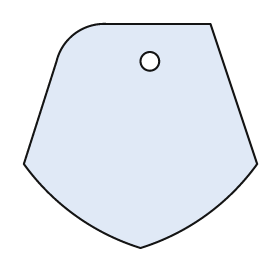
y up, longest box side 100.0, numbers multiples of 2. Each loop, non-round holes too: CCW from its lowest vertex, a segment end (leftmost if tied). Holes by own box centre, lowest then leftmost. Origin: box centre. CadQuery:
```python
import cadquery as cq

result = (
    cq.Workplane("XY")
    .moveTo(0.0, -48.0)
    .threePointArc((28.0, -34.0), (50.0, -12.0))
    .lineTo(30.0, 48.0)
    .lineTo(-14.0, 48.0)
    .threePointArc((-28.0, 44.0), (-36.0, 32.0))
    .lineTo(-50.0, -12.0)
    .threePointArc((-28.0, -34.0), (0.0, -48.0))
    .close()
    .moveTo(4.0, 32.0)
    .circle(4.0)
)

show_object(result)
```